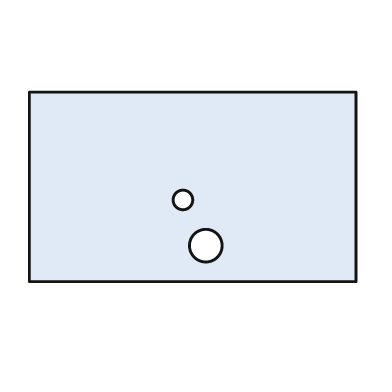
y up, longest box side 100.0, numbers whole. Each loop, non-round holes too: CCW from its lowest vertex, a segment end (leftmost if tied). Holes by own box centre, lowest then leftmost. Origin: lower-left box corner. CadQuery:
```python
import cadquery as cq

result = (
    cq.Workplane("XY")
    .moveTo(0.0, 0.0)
    .lineTo(100.0, 0.0)
    .lineTo(100.0, 58.0)
    .lineTo(0.0, 58.0)
    .close()
    .moveTo(54.0, 11.0)
    .circle(5.0)
    .moveTo(47.0, 25.0)
    .circle(3.0)
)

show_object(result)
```